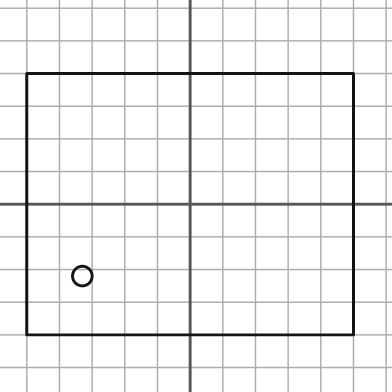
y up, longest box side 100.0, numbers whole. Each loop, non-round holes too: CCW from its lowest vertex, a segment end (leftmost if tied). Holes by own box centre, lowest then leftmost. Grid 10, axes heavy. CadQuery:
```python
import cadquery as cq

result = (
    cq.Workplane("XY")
    .moveTo(-50.0, -40.0)
    .lineTo(50.0, -40.0)
    .lineTo(50.0, 40.0)
    .lineTo(-50.0, 40.0)
    .close()
    .moveTo(-33.0, -22.0)
    .circle(3.0)
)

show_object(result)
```